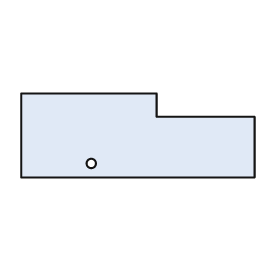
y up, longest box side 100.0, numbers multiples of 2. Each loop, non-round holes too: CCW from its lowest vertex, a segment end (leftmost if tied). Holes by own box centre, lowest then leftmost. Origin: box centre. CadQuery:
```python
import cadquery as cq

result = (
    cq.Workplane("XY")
    .moveTo(-50.0, -18.0)
    .lineTo(50.0, -18.0)
    .lineTo(50.0, 8.0)
    .lineTo(8.0, 8.0)
    .lineTo(8.0, 18.0)
    .lineTo(-50.0, 18.0)
    .close()
    .moveTo(-20.0, -12.0)
    .circle(2.0)
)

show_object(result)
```